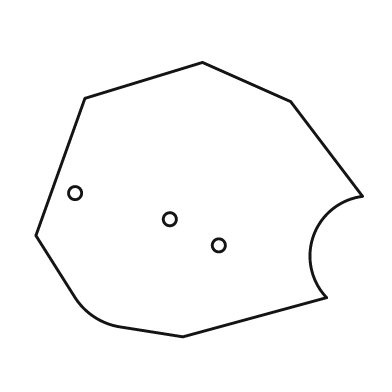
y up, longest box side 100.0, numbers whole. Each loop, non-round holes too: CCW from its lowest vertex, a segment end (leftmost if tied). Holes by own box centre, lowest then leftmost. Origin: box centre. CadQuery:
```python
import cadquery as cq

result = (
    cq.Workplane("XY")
    .moveTo(-5.0, -42.0)
    .lineTo(39.0, -30.0)
    .threePointArc((35.0, -11.0), (50.0, 1.0))
    .lineTo(28.0, 30.0)
    .lineTo(1.0, 42.0)
    .lineTo(-35.0, 31.0)
    .lineTo(-50.0, -11.0)
    .lineTo(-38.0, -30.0)
    .threePointArc((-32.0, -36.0), (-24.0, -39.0))
    .close()
    .moveTo(6.0, -14.0)
    .circle(2.0)
    .moveTo(-9.0, -6.0)
    .circle(2.0)
    .moveTo(-38.0, 2.0)
    .circle(2.0)
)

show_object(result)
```